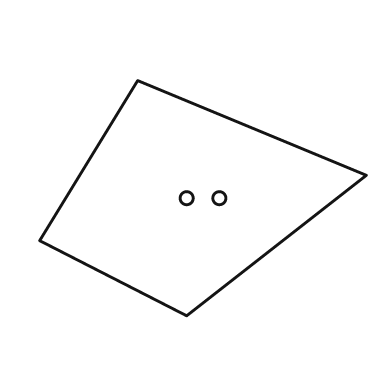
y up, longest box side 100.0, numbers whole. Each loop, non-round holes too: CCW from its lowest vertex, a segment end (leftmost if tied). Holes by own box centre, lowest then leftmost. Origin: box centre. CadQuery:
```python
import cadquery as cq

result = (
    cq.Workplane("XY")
    .moveTo(-5.0, -36.0)
    .lineTo(50.0, 7.0)
    .lineTo(-20.0, 36.0)
    .lineTo(-50.0, -13.0)
    .close()
    .moveTo(-5.0, 0.0)
    .circle(2.0)
    .moveTo(5.0, 0.0)
    .circle(2.0)
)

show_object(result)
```